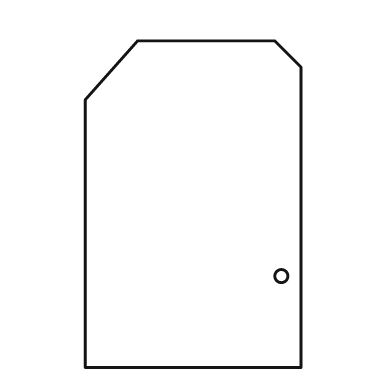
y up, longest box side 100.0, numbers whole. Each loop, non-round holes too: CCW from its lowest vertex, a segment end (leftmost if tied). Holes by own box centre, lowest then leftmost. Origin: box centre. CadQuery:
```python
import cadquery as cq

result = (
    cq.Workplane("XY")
    .moveTo(-33.0, -50.0)
    .lineTo(33.0, -50.0)
    .lineTo(33.0, 42.0)
    .lineTo(25.0, 50.0)
    .lineTo(-17.0, 50.0)
    .lineTo(-33.0, 32.0)
    .close()
    .moveTo(27.0, -22.0)
    .circle(2.0)
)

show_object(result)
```